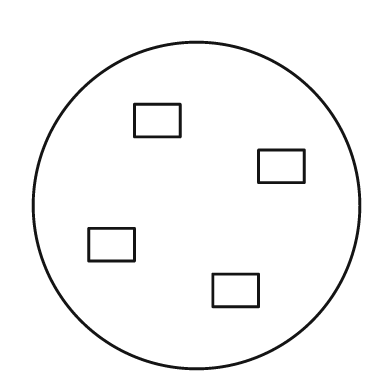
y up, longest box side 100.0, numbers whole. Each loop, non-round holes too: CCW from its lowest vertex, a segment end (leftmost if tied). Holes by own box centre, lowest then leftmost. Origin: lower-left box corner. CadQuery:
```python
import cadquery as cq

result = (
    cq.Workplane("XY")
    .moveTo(50.0, 50.0)
    .circle(50.0)
    .moveTo(55.0, 19.0)
    .lineTo(69.0, 19.0)
    .lineTo(69.0, 29.0)
    .lineTo(55.0, 29.0)
    .close()
    .moveTo(17.0, 33.0)
    .lineTo(31.0, 33.0)
    .lineTo(31.0, 43.0)
    .lineTo(17.0, 43.0)
    .close()
    .moveTo(69.0, 57.0)
    .lineTo(83.0, 57.0)
    .lineTo(83.0, 67.0)
    .lineTo(69.0, 67.0)
    .close()
    .moveTo(31.0, 71.0)
    .lineTo(45.0, 71.0)
    .lineTo(45.0, 81.0)
    .lineTo(31.0, 81.0)
    .close()
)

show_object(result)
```